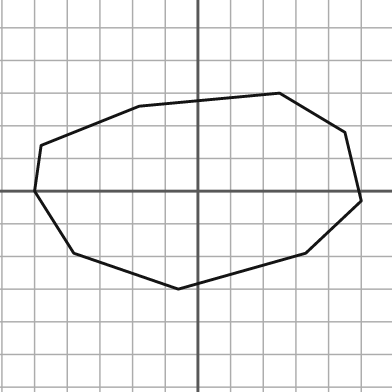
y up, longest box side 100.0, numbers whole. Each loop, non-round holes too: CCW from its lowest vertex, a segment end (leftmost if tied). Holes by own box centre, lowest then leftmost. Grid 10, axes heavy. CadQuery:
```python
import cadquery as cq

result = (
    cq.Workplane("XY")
    .moveTo(-6.0, -30.0)
    .lineTo(33.0, -19.0)
    .lineTo(50.0, -3.0)
    .lineTo(45.0, 18.0)
    .lineTo(25.0, 30.0)
    .lineTo(-18.0, 26.0)
    .lineTo(-48.0, 14.0)
    .lineTo(-50.0, 0.0)
    .lineTo(-38.0, -19.0)
    .close()
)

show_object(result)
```